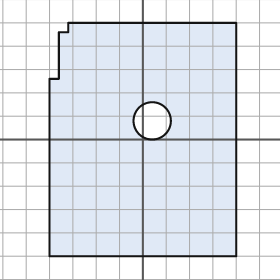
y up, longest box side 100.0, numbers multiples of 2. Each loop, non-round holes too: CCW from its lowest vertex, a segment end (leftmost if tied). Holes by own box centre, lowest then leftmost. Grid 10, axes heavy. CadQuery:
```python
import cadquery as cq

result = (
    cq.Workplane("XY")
    .moveTo(-40.0, -50.0)
    .lineTo(40.0, -50.0)
    .lineTo(40.0, 50.0)
    .lineTo(-32.0, 50.0)
    .lineTo(-32.0, 46.0)
    .lineTo(-36.0, 46.0)
    .lineTo(-36.0, 26.0)
    .lineTo(-40.0, 26.0)
    .close()
    .moveTo(4.0, 8.0)
    .circle(8.0)
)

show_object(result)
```